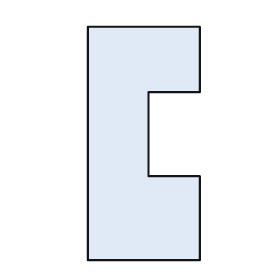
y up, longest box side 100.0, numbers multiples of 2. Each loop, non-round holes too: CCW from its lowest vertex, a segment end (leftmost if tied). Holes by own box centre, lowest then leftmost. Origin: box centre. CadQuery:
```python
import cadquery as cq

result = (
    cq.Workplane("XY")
    .moveTo(-24.0, -50.0)
    .lineTo(24.0, -50.0)
    .lineTo(24.0, -14.0)
    .lineTo(2.0, -14.0)
    .lineTo(2.0, 22.0)
    .lineTo(24.0, 22.0)
    .lineTo(24.0, 50.0)
    .lineTo(-24.0, 50.0)
    .close()
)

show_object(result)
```